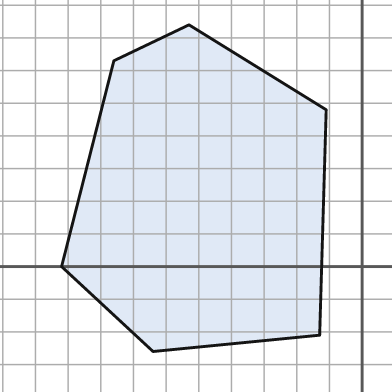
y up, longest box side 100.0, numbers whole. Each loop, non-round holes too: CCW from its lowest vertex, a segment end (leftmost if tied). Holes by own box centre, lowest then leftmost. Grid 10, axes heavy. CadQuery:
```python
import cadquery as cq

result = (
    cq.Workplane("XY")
    .moveTo(-64.0, -26.0)
    .lineTo(-13.0, -21.0)
    .lineTo(-11.0, 48.0)
    .lineTo(-53.0, 74.0)
    .lineTo(-76.0, 63.0)
    .lineTo(-92.0, 0.0)
    .close()
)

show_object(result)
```